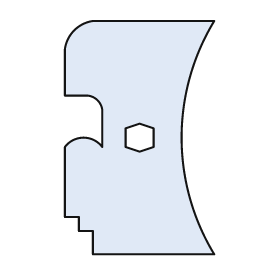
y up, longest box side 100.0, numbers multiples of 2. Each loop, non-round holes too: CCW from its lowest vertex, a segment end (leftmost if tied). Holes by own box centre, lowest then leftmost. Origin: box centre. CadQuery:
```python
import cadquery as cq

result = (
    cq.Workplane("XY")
    .moveTo(-20.0, -50.0)
    .lineTo(32.0, -50.0)
    .threePointArc((18.0, 0.0), (32.0, 50.0))
    .lineTo(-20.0, 50.0)
    .threePointArc((-28.0, 46.0), (-32.0, 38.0))
    .lineTo(-32.0, 18.0)
    .lineTo(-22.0, 18.0)
    .threePointArc((-18.0, 16.0), (-16.0, 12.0))
    .lineTo(-16.0, -4.0)
    .threePointArc((-24.0, 0.0), (-32.0, -4.0))
    .lineTo(-32.0, -34.0)
    .lineTo(-26.0, -34.0)
    .lineTo(-26.0, -40.0)
    .lineTo(-20.0, -40.0)
    .close()
    .moveTo(0.0, -6.0)
    .lineTo(6.0, -4.0)
    .lineTo(6.0, 4.0)
    .lineTo(0.0, 6.0)
    .lineTo(-6.0, 4.0)
    .lineTo(-6.0, -4.0)
    .close()
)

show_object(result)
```